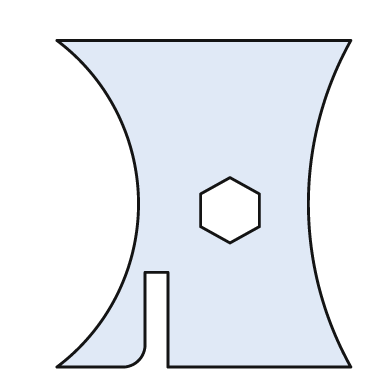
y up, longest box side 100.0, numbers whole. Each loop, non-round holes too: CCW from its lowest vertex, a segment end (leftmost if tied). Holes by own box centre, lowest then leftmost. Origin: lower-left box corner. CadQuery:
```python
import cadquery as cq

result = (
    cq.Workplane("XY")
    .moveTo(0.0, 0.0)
    .lineTo(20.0, 0.0)
    .threePointArc((25.0, 2.0), (27.0, 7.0))
    .lineTo(27.0, 29.0)
    .lineTo(34.0, 29.0)
    .lineTo(34.0, 0.0)
    .lineTo(90.0, 0.0)
    .threePointArc((77.0, 50.0), (90.0, 100.0))
    .lineTo(0.0, 100.0)
    .threePointArc((25.0, 50.0), (0.0, 0.0))
    .close()
    .moveTo(53.0, 38.0)
    .lineTo(62.0, 43.0)
    .lineTo(62.0, 53.0)
    .lineTo(53.0, 58.0)
    .lineTo(44.0, 53.0)
    .lineTo(44.0, 43.0)
    .close()
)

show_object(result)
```